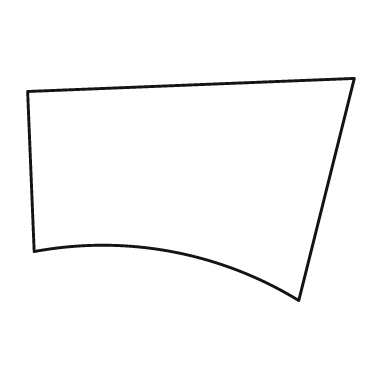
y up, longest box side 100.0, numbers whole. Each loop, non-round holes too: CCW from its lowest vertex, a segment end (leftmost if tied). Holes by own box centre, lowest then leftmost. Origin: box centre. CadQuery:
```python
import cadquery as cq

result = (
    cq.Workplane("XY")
    .moveTo(33.0, -34.0)
    .lineTo(50.0, 34.0)
    .lineTo(-50.0, 30.0)
    .lineTo(-48.0, -19.0)
    .threePointArc((-6.0, -19.0), (33.0, -34.0))
    .close()
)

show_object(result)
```